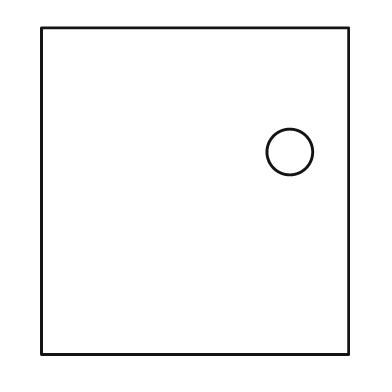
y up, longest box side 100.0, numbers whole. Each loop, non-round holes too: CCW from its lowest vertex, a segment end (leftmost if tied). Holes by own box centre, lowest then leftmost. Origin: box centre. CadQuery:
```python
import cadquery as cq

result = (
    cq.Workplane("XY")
    .moveTo(-47.0, -50.0)
    .lineTo(47.0, -50.0)
    .lineTo(47.0, 50.0)
    .lineTo(-47.0, 50.0)
    .close()
    .moveTo(29.0, 12.0)
    .circle(7.0)
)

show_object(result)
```